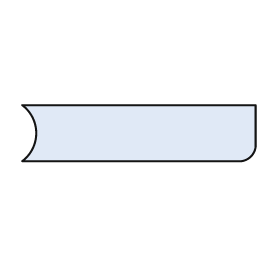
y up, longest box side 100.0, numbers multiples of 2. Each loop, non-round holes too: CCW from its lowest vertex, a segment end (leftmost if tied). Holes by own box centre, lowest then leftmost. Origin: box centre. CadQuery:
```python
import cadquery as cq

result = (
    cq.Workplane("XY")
    .moveTo(-50.0, -12.0)
    .lineTo(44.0, -12.0)
    .threePointArc((48.0, -10.0), (50.0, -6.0))
    .lineTo(50.0, 12.0)
    .lineTo(-50.0, 12.0)
    .threePointArc((-44.0, 0.0), (-50.0, -12.0))
    .close()
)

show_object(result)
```